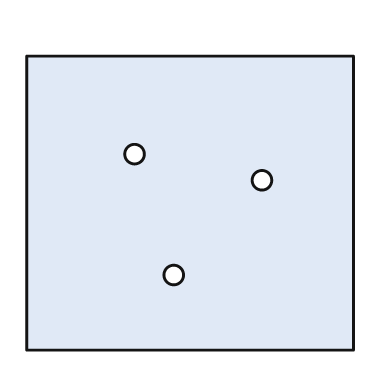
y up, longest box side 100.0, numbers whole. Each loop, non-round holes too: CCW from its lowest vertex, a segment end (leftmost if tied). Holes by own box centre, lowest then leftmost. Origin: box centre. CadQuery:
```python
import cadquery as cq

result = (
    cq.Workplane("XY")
    .moveTo(-50.0, -45.0)
    .lineTo(50.0, -45.0)
    .lineTo(50.0, 45.0)
    .lineTo(-50.0, 45.0)
    .close()
    .moveTo(-5.0, -22.0)
    .circle(3.0)
    .moveTo(22.0, 7.0)
    .circle(3.0)
    .moveTo(-17.0, 15.0)
    .circle(3.0)
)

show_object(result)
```